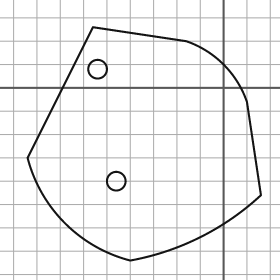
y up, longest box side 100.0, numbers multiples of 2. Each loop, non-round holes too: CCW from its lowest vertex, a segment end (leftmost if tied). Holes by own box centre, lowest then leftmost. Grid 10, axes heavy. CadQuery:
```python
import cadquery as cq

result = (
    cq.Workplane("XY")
    .moveTo(-40.0, -74.0)
    .threePointArc((-10.0, -64.0), (16.0, -46.0))
    .lineTo(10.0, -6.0)
    .threePointArc((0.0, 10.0), (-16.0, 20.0))
    .lineTo(-56.0, 26.0)
    .lineTo(-84.0, -30.0)
    .threePointArc((-68.0, -58.0), (-40.0, -74.0))
    .close()
    .moveTo(-46.0, -40.0)
    .circle(4.0)
    .moveTo(-54.0, 8.0)
    .circle(4.0)
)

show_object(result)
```